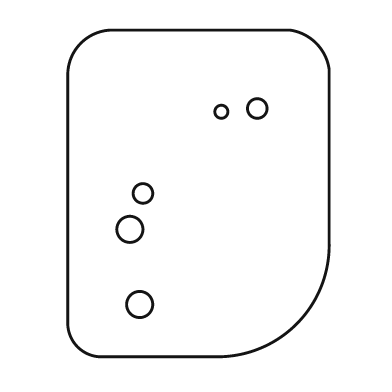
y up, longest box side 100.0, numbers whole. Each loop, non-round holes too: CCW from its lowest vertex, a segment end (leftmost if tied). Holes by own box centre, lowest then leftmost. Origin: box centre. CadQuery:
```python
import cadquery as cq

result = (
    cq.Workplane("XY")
    .moveTo(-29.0, -50.0)
    .lineTo(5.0, -50.0)
    .threePointArc((30.0, -40.0), (40.0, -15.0))
    .lineTo(40.0, 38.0)
    .threePointArc((36.0, 46.0), (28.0, 50.0))
    .lineTo(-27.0, 50.0)
    .threePointArc((-36.0, 46.0), (-40.0, 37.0))
    .lineTo(-40.0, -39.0)
    .threePointArc((-37.0, -47.0), (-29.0, -50.0))
    .close()
    .moveTo(-18.0, -34.0)
    .circle(4.0)
    .moveTo(-21.0, -11.0)
    .circle(4.0)
    .moveTo(-17.0, 0.0)
    .circle(3.0)
    .moveTo(7.0, 25.0)
    .circle(2.0)
    .moveTo(18.0, 26.0)
    .circle(3.0)
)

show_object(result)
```